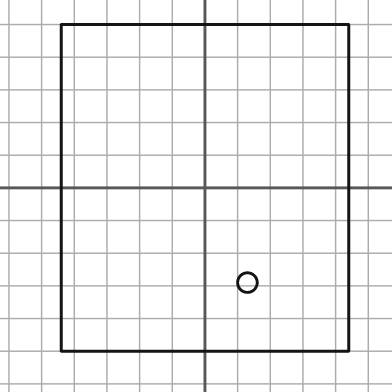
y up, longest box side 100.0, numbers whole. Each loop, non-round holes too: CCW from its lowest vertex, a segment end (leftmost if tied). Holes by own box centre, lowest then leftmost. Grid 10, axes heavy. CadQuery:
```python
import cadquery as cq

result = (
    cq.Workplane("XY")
    .moveTo(-44.0, -50.0)
    .lineTo(44.0, -50.0)
    .lineTo(44.0, 50.0)
    .lineTo(-44.0, 50.0)
    .close()
    .moveTo(13.0, -29.0)
    .circle(3.0)
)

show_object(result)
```